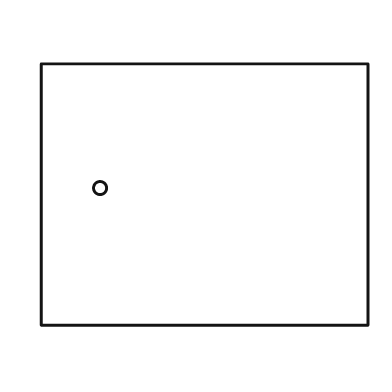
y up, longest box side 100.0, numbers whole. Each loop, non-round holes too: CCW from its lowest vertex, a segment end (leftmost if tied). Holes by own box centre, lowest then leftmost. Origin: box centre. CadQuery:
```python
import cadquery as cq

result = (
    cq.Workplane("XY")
    .moveTo(-50.0, -40.0)
    .lineTo(50.0, -40.0)
    .lineTo(50.0, 40.0)
    .lineTo(-50.0, 40.0)
    .close()
    .moveTo(-32.0, 2.0)
    .circle(2.0)
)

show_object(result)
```